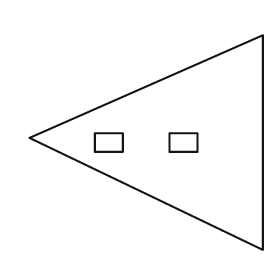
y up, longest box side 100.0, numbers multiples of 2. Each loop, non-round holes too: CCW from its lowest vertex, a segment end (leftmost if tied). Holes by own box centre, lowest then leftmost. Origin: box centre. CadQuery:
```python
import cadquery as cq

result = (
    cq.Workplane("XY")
    .moveTo(50.0, -46.0)
    .lineTo(50.0, 46.0)
    .lineTo(-50.0, 2.0)
    .close()
    .moveTo(-22.0, -4.0)
    .lineTo(-10.0, -4.0)
    .lineTo(-10.0, 4.0)
    .lineTo(-22.0, 4.0)
    .close()
    .moveTo(10.0, -4.0)
    .lineTo(22.0, -4.0)
    .lineTo(22.0, 4.0)
    .lineTo(10.0, 4.0)
    .close()
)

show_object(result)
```